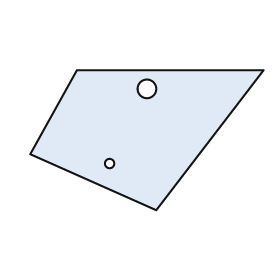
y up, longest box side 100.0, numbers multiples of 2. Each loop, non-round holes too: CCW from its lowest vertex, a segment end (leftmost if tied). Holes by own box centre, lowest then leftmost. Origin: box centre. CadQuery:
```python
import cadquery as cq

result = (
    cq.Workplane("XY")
    .moveTo(4.0, -30.0)
    .lineTo(50.0, 30.0)
    .lineTo(-30.0, 30.0)
    .lineTo(-50.0, -6.0)
    .close()
    .moveTo(-16.0, -10.0)
    .circle(2.0)
    .moveTo(0.0, 22.0)
    .circle(4.0)
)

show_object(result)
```